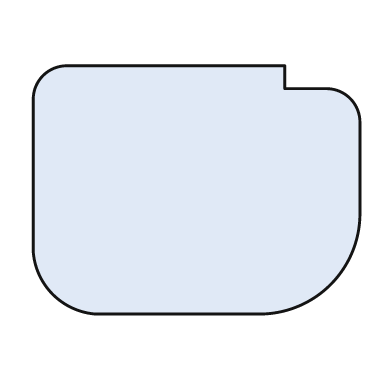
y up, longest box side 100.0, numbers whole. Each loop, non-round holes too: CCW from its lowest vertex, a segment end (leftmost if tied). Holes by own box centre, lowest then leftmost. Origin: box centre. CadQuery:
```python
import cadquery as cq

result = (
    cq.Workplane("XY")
    .moveTo(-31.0, -38.0)
    .lineTo(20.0, -38.0)
    .threePointArc((41.0, -29.0), (50.0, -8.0))
    .lineTo(50.0, 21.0)
    .threePointArc((47.0, 28.0), (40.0, 31.0))
    .lineTo(27.0, 31.0)
    .lineTo(27.0, 38.0)
    .lineTo(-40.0, 38.0)
    .threePointArc((-47.0, 35.0), (-50.0, 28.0))
    .lineTo(-50.0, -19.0)
    .threePointArc((-44.0, -32.0), (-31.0, -38.0))
    .close()
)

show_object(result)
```